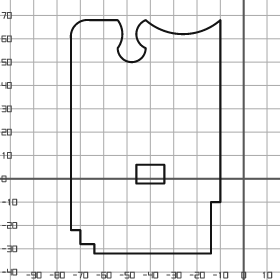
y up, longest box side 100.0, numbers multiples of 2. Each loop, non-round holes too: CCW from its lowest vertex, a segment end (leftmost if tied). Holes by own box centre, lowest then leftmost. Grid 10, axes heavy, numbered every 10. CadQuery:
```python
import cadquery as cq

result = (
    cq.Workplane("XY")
    .moveTo(-64.0, -32.0)
    .lineTo(-14.0, -32.0)
    .lineTo(-14.0, -10.0)
    .lineTo(-10.0, -10.0)
    .lineTo(-10.0, 68.0)
    .threePointArc((-26.0, 62.0), (-42.0, 68.0))
    .threePointArc((-46.0, 62.0), (-42.0, 56.0))
    .threePointArc((-48.0, 50.0), (-54.0, 56.0))
    .threePointArc((-52.0, 62.0), (-54.0, 68.0))
    .lineTo(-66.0, 68.0)
    .threePointArc((-72.0, 66.0), (-74.0, 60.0))
    .lineTo(-74.0, -22.0)
    .lineTo(-70.0, -22.0)
    .lineTo(-70.0, -28.0)
    .lineTo(-64.0, -28.0)
    .close()
    .moveTo(-46.0, -2.0)
    .lineTo(-34.0, -2.0)
    .lineTo(-34.0, 6.0)
    .lineTo(-46.0, 6.0)
    .close()
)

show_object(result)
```